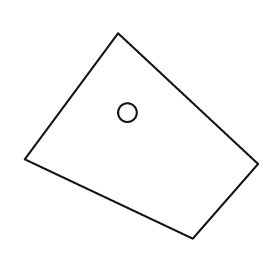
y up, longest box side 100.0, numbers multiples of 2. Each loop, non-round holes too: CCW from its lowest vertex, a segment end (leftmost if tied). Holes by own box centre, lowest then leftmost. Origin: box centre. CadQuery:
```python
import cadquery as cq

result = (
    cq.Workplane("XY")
    .moveTo(22.0, -44.0)
    .lineTo(50.0, -12.0)
    .lineTo(-10.0, 44.0)
    .lineTo(-50.0, -10.0)
    .close()
    .moveTo(-6.0, 10.0)
    .circle(4.0)
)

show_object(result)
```